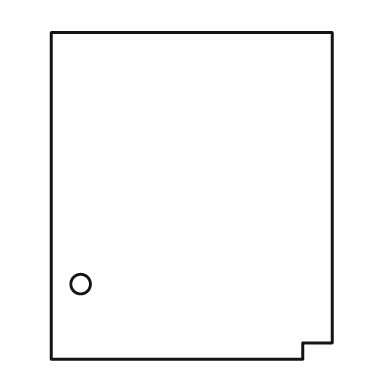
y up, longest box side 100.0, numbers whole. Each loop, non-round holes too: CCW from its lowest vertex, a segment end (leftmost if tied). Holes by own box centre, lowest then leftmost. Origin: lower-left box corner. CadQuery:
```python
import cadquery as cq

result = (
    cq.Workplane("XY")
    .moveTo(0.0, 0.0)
    .lineTo(77.0, 0.0)
    .lineTo(77.0, 5.0)
    .lineTo(86.0, 5.0)
    .lineTo(86.0, 100.0)
    .lineTo(0.0, 100.0)
    .close()
    .moveTo(9.0, 23.0)
    .circle(3.0)
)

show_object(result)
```